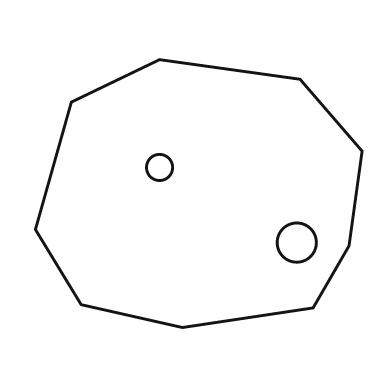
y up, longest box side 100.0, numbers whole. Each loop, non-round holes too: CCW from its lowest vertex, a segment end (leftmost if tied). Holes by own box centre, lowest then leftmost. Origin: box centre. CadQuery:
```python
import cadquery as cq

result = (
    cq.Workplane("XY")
    .moveTo(-5.0, -41.0)
    .lineTo(35.0, -35.0)
    .lineTo(46.0, -16.0)
    .lineTo(50.0, 13.0)
    .lineTo(31.0, 35.0)
    .lineTo(-12.0, 41.0)
    .lineTo(-39.0, 28.0)
    .lineTo(-50.0, -11.0)
    .lineTo(-36.0, -34.0)
    .close()
    .moveTo(30.0, -15.0)
    .circle(6.0)
    .moveTo(-12.0, 8.0)
    .circle(4.0)
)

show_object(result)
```